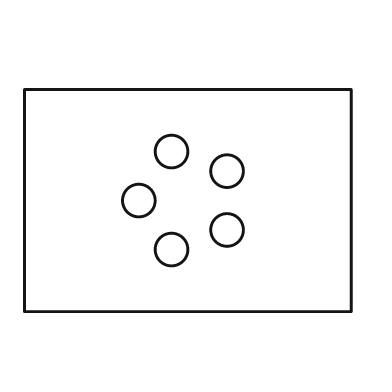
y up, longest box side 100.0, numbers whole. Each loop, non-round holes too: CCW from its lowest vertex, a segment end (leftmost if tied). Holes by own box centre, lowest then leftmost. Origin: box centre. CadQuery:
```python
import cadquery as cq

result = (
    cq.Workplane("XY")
    .moveTo(-50.0, -34.0)
    .lineTo(50.0, -34.0)
    .lineTo(50.0, 34.0)
    .lineTo(-50.0, 34.0)
    .close()
    .moveTo(-5.0, -15.0)
    .circle(5.0)
    .moveTo(12.0, -9.0)
    .circle(5.0)
    .moveTo(-15.0, 0.0)
    .circle(5.0)
    .moveTo(12.0, 9.0)
    .circle(5.0)
    .moveTo(-5.0, 15.0)
    .circle(5.0)
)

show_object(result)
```